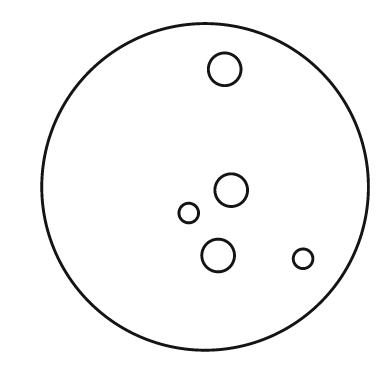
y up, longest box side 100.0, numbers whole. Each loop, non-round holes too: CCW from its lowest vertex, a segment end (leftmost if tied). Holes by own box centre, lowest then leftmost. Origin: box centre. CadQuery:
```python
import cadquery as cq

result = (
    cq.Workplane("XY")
    .moveTo(0.0, 0.0)
    .circle(50.0)
    .moveTo(30.0, -22.0)
    .circle(3.0)
    .moveTo(4.0, -21.0)
    .circle(5.0)
    .moveTo(-5.0, -8.0)
    .circle(3.0)
    .moveTo(8.0, -1.0)
    .circle(5.0)
    .moveTo(6.0, 36.0)
    .circle(5.0)
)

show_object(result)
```